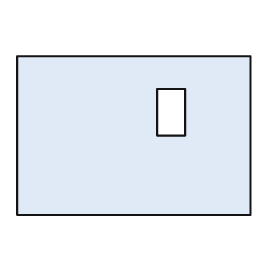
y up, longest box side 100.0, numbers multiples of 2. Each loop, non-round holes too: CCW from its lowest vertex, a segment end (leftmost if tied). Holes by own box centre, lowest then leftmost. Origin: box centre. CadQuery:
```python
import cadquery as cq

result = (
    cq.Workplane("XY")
    .moveTo(-50.0, -34.0)
    .lineTo(50.0, -34.0)
    .lineTo(50.0, 34.0)
    .lineTo(-50.0, 34.0)
    .close()
    .moveTo(10.0, 0.0)
    .lineTo(22.0, 0.0)
    .lineTo(22.0, 20.0)
    .lineTo(10.0, 20.0)
    .close()
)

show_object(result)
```